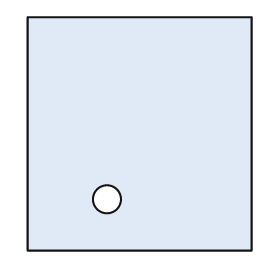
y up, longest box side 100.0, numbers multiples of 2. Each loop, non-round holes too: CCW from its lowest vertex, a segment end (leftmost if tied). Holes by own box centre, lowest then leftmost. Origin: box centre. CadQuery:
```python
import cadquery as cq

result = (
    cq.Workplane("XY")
    .moveTo(-48.0, -50.0)
    .lineTo(48.0, -50.0)
    .lineTo(48.0, 50.0)
    .lineTo(-48.0, 50.0)
    .close()
    .moveTo(-14.0, -28.0)
    .circle(6.0)
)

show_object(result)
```